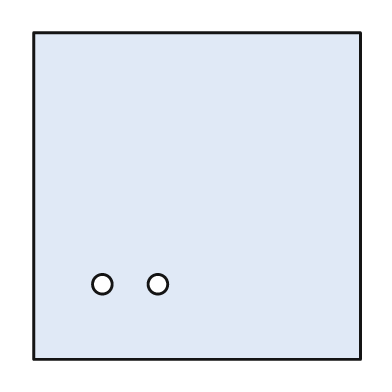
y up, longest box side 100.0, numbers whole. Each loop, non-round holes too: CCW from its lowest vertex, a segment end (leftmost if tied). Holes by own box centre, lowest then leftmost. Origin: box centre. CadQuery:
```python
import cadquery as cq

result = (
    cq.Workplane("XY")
    .moveTo(-50.0, -50.0)
    .lineTo(50.0, -50.0)
    .lineTo(50.0, 50.0)
    .lineTo(-50.0, 50.0)
    .close()
    .moveTo(-29.0, -27.0)
    .circle(3.0)
    .moveTo(-12.0, -27.0)
    .circle(3.0)
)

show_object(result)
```